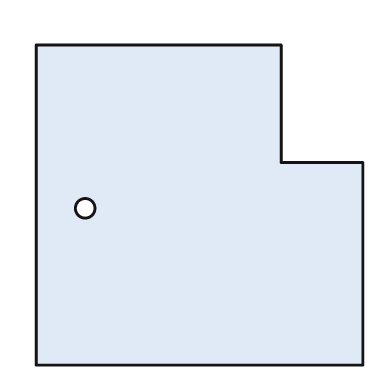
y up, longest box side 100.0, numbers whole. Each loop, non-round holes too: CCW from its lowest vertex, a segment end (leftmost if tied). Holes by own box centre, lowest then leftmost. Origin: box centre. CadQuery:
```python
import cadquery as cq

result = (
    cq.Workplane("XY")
    .moveTo(-50.0, -49.0)
    .lineTo(50.0, -49.0)
    .lineTo(50.0, 13.0)
    .lineTo(25.0, 13.0)
    .lineTo(25.0, 49.0)
    .lineTo(-50.0, 49.0)
    .close()
    .moveTo(-35.0, -1.0)
    .circle(3.0)
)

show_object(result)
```